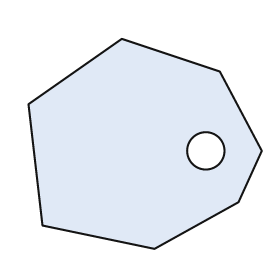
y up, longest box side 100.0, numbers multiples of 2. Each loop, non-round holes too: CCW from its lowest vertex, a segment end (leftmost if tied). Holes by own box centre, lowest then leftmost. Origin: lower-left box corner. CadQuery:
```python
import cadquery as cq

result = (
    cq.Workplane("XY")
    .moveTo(54.0, 0.0)
    .lineTo(90.0, 20.0)
    .lineTo(100.0, 42.0)
    .lineTo(82.0, 76.0)
    .lineTo(40.0, 90.0)
    .lineTo(0.0, 62.0)
    .lineTo(6.0, 10.0)
    .close()
    .moveTo(76.0, 42.0)
    .circle(8.0)
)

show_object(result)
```